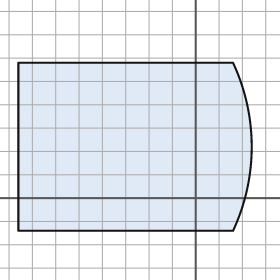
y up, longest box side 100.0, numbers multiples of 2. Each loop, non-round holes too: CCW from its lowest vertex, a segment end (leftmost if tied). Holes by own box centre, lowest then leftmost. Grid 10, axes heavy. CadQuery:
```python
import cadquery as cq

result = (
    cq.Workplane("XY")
    .moveTo(-76.0, -14.0)
    .lineTo(16.0, -14.0)
    .threePointArc((24.0, 22.0), (16.0, 58.0))
    .lineTo(-76.0, 58.0)
    .close()
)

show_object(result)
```